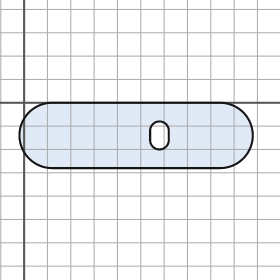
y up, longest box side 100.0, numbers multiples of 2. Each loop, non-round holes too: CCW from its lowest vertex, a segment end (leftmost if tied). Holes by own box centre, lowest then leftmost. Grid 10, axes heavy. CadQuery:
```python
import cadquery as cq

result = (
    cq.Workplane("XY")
    .moveTo(12.0, -28.0)
    .lineTo(84.0, -28.0)
    .threePointArc((98.0, -14.0), (84.0, 0.0))
    .lineTo(12.0, 0.0)
    .threePointArc((-2.0, -14.0), (12.0, -28.0))
    .close()
    .moveTo(54.0, -16.0)
    .threePointArc((58.0, -20.0), (62.0, -16.0))
    .lineTo(62.0, -12.0)
    .threePointArc((58.0, -8.0), (54.0, -12.0))
    .close()
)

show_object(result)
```